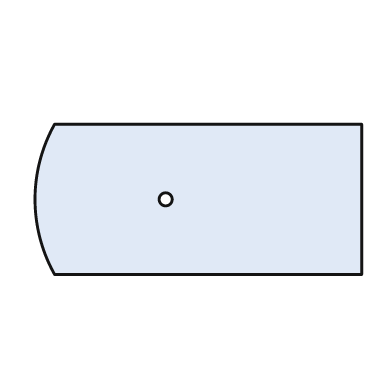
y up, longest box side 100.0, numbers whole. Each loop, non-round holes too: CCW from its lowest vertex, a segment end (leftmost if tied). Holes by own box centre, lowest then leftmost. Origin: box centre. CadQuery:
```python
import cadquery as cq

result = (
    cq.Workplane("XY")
    .moveTo(-44.0, -23.0)
    .lineTo(50.0, -23.0)
    .lineTo(50.0, 23.0)
    .lineTo(-44.0, 23.0)
    .threePointArc((-50.0, 0.0), (-44.0, -23.0))
    .close()
    .moveTo(-10.0, 0.0)
    .circle(2.0)
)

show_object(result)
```